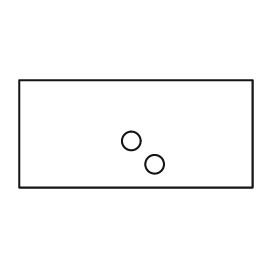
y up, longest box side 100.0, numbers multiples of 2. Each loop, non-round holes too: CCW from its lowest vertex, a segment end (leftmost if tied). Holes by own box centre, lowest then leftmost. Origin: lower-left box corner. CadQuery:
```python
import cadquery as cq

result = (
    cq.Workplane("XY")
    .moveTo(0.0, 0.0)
    .lineTo(100.0, 0.0)
    .lineTo(100.0, 46.0)
    .lineTo(0.0, 46.0)
    .close()
    .moveTo(58.0, 10.0)
    .circle(4.0)
    .moveTo(48.0, 20.0)
    .circle(4.0)
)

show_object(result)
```